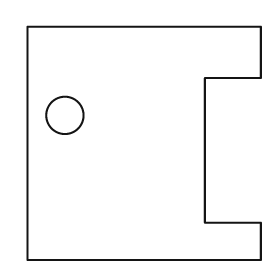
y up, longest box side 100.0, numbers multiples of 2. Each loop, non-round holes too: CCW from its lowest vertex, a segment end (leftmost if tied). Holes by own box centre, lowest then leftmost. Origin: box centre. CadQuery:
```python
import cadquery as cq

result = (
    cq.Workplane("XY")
    .moveTo(-50.0, -50.0)
    .lineTo(50.0, -50.0)
    .lineTo(50.0, -34.0)
    .lineTo(26.0, -34.0)
    .lineTo(26.0, 28.0)
    .lineTo(50.0, 28.0)
    .lineTo(50.0, 50.0)
    .lineTo(-50.0, 50.0)
    .close()
    .moveTo(-34.0, 12.0)
    .circle(8.0)
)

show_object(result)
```